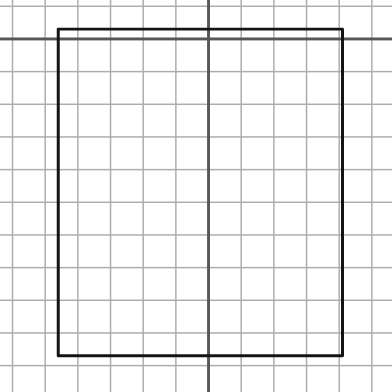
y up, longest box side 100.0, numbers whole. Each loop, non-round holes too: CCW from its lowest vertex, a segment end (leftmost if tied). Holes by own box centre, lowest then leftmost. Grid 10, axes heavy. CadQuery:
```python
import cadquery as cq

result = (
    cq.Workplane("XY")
    .moveTo(-46.0, -97.0)
    .lineTo(41.0, -97.0)
    .lineTo(41.0, 3.0)
    .lineTo(-46.0, 3.0)
    .close()
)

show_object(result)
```